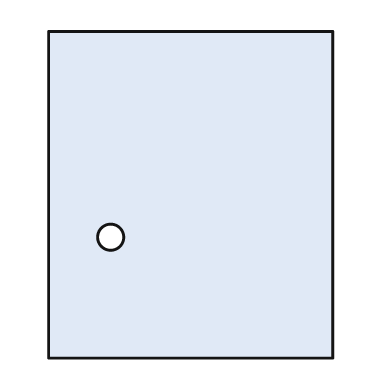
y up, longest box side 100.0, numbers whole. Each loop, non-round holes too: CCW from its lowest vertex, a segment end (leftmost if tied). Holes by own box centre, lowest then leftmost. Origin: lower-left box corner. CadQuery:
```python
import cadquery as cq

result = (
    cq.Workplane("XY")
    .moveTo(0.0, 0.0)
    .lineTo(87.0, 0.0)
    .lineTo(87.0, 100.0)
    .lineTo(0.0, 100.0)
    .close()
    .moveTo(19.0, 37.0)
    .circle(4.0)
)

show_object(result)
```